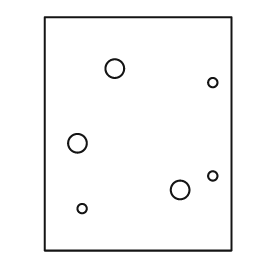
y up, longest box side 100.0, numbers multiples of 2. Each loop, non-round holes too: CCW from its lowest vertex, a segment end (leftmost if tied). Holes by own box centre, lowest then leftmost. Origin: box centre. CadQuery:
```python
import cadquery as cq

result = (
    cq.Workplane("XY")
    .moveTo(-40.0, -50.0)
    .lineTo(40.0, -50.0)
    .lineTo(40.0, 50.0)
    .lineTo(-40.0, 50.0)
    .close()
    .moveTo(-24.0, -32.0)
    .circle(2.0)
    .moveTo(18.0, -24.0)
    .circle(4.0)
    .moveTo(32.0, -18.0)
    .circle(2.0)
    .moveTo(-26.0, -4.0)
    .circle(4.0)
    .moveTo(32.0, 22.0)
    .circle(2.0)
    .moveTo(-10.0, 28.0)
    .circle(4.0)
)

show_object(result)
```